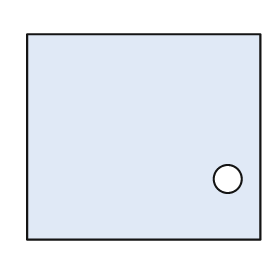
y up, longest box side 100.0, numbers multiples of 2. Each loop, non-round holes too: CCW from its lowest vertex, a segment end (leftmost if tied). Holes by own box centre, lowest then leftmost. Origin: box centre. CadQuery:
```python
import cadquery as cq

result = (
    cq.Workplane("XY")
    .moveTo(-50.0, -44.0)
    .lineTo(50.0, -44.0)
    .lineTo(50.0, 44.0)
    .lineTo(-50.0, 44.0)
    .close()
    .moveTo(36.0, -18.0)
    .circle(6.0)
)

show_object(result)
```